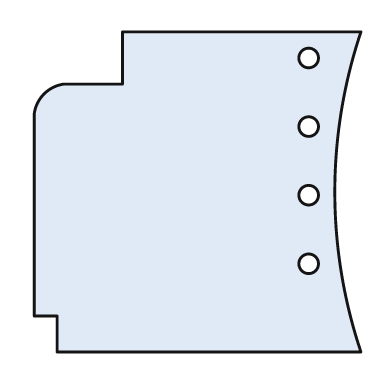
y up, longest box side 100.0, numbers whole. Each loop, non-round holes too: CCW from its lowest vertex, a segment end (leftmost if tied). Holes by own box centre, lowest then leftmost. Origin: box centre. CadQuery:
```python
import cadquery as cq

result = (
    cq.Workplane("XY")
    .moveTo(-43.0, -49.0)
    .lineTo(50.0, -49.0)
    .threePointArc((42.0, 0.0), (50.0, 49.0))
    .lineTo(-23.0, 49.0)
    .lineTo(-23.0, 33.0)
    .lineTo(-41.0, 33.0)
    .threePointArc((-47.0, 30.0), (-50.0, 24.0))
    .lineTo(-50.0, -38.0)
    .lineTo(-43.0, -38.0)
    .close()
    .moveTo(34.0, -22.0)
    .circle(3.0)
    .moveTo(34.0, -1.0)
    .circle(3.0)
    .moveTo(34.0, 20.0)
    .circle(3.0)
    .moveTo(34.0, 41.0)
    .circle(3.0)
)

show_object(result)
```